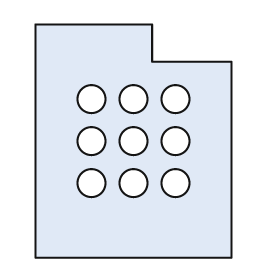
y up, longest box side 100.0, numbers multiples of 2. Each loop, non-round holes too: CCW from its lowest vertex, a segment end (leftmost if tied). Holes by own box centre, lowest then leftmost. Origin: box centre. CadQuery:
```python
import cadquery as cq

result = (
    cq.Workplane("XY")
    .moveTo(-42.0, -50.0)
    .lineTo(42.0, -50.0)
    .lineTo(42.0, 34.0)
    .lineTo(8.0, 34.0)
    .lineTo(8.0, 50.0)
    .lineTo(-42.0, 50.0)
    .close()
    .moveTo(-18.0, -18.0)
    .circle(6.0)
    .moveTo(0.0, -18.0)
    .circle(6.0)
    .moveTo(18.0, -18.0)
    .circle(6.0)
    .moveTo(-18.0, 0.0)
    .circle(6.0)
    .moveTo(0.0, 0.0)
    .circle(6.0)
    .moveTo(18.0, 0.0)
    .circle(6.0)
    .moveTo(-18.0, 18.0)
    .circle(6.0)
    .moveTo(0.0, 18.0)
    .circle(6.0)
    .moveTo(18.0, 18.0)
    .circle(6.0)
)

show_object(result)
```